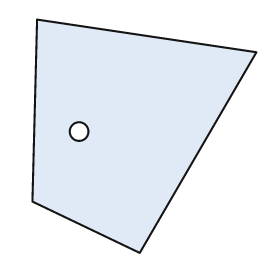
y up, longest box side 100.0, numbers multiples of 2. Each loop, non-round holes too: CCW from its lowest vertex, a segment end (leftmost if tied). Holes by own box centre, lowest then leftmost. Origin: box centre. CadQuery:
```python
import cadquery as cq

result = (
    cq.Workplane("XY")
    .moveTo(-2.0, -50.0)
    .lineTo(48.0, 36.0)
    .lineTo(-46.0, 50.0)
    .lineTo(-48.0, -28.0)
    .close()
    .moveTo(-28.0, 2.0)
    .circle(4.0)
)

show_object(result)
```